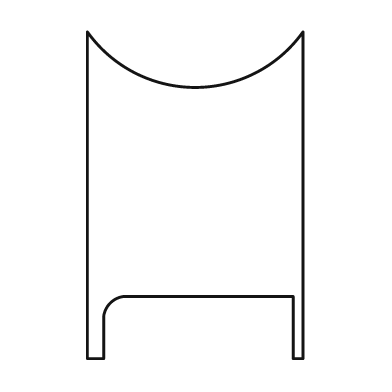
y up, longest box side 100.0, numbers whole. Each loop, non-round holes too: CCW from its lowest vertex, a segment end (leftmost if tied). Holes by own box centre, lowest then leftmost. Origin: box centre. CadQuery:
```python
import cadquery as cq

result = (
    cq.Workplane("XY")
    .moveTo(-33.0, -50.0)
    .lineTo(-28.0, -50.0)
    .lineTo(-28.0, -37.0)
    .threePointArc((-26.0, -33.0), (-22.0, -31.0))
    .lineTo(30.0, -31.0)
    .lineTo(30.0, -50.0)
    .lineTo(33.0, -50.0)
    .lineTo(33.0, 50.0)
    .threePointArc((0.0, 33.0), (-33.0, 50.0))
    .close()
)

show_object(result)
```